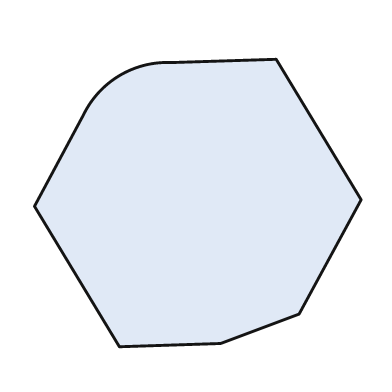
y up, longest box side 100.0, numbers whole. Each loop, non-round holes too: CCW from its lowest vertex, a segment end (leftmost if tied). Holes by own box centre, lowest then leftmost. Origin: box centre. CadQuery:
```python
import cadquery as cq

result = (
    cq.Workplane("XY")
    .moveTo(-24.0, -44.0)
    .lineTo(7.0, -43.0)
    .lineTo(31.0, -34.0)
    .lineTo(50.0, 1.0)
    .lineTo(24.0, 44.0)
    .lineTo(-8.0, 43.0)
    .threePointArc((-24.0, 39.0), (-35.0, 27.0))
    .lineTo(-50.0, -1.0)
    .close()
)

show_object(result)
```